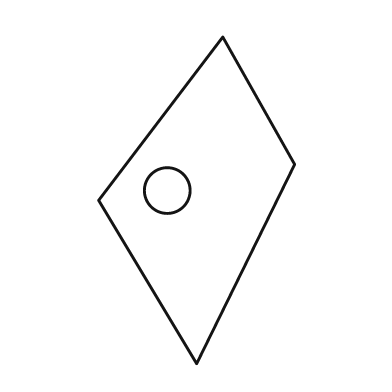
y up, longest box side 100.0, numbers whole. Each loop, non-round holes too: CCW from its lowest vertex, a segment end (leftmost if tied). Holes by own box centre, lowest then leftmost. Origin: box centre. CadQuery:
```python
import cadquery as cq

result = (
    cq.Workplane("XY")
    .moveTo(0.0, -50.0)
    .lineTo(30.0, 11.0)
    .lineTo(8.0, 50.0)
    .lineTo(-30.0, 0.0)
    .close()
    .moveTo(-9.0, 3.0)
    .circle(7.0)
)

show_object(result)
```